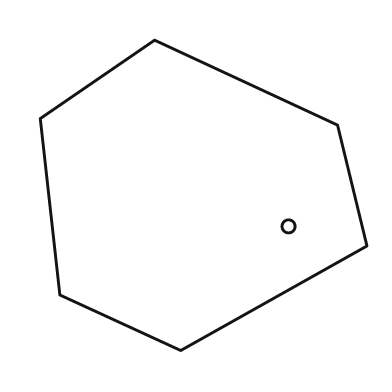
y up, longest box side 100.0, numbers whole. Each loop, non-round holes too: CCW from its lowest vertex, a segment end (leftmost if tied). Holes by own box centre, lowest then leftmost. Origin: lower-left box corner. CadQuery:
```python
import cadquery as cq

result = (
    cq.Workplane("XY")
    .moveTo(43.0, 0.0)
    .lineTo(100.0, 32.0)
    .lineTo(91.0, 69.0)
    .lineTo(35.0, 95.0)
    .lineTo(0.0, 71.0)
    .lineTo(6.0, 17.0)
    .close()
    .moveTo(76.0, 38.0)
    .circle(2.0)
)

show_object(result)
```